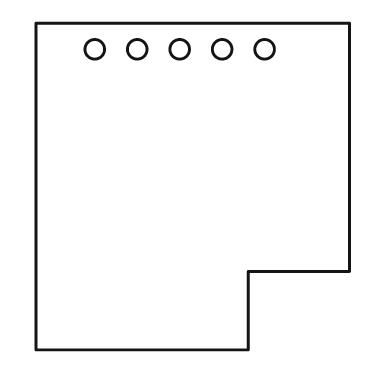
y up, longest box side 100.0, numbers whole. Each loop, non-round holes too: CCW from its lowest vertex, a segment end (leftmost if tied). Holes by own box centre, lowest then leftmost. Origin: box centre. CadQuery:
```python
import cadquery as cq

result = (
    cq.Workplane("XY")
    .moveTo(-48.0, -50.0)
    .lineTo(17.0, -50.0)
    .lineTo(17.0, -26.0)
    .lineTo(48.0, -26.0)
    .lineTo(48.0, 50.0)
    .lineTo(-48.0, 50.0)
    .close()
    .moveTo(-30.0, 42.0)
    .circle(3.0)
    .moveTo(-17.0, 42.0)
    .circle(3.0)
    .moveTo(-4.0, 42.0)
    .circle(3.0)
    .moveTo(9.0, 42.0)
    .circle(3.0)
    .moveTo(22.0, 42.0)
    .circle(3.0)
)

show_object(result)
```